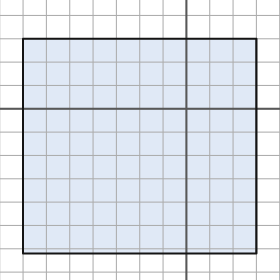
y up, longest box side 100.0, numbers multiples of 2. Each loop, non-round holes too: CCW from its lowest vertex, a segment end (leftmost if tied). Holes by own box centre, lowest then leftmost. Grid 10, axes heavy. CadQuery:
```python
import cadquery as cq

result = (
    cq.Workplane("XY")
    .moveTo(-70.0, -62.0)
    .lineTo(30.0, -62.0)
    .lineTo(30.0, 30.0)
    .lineTo(-70.0, 30.0)
    .close()
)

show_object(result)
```